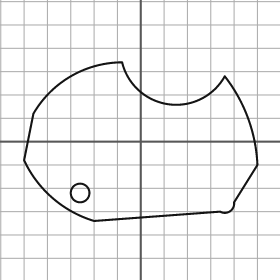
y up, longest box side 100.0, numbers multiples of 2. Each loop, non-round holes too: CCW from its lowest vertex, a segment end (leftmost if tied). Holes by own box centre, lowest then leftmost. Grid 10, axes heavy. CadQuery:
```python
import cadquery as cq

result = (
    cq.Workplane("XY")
    .moveTo(-20.0, -34.0)
    .lineTo(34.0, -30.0)
    .threePointArc((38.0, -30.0), (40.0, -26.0))
    .lineTo(50.0, -10.0)
    .threePointArc((46.0, 10.0), (36.0, 28.0))
    .threePointArc((12.0, 16.0), (-8.0, 34.0))
    .threePointArc((-30.0, 28.0), (-46.0, 12.0))
    .lineTo(-50.0, -8.0)
    .threePointArc((-38.0, -24.0), (-20.0, -34.0))
    .close()
    .moveTo(-26.0, -22.0)
    .circle(4.0)
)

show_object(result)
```